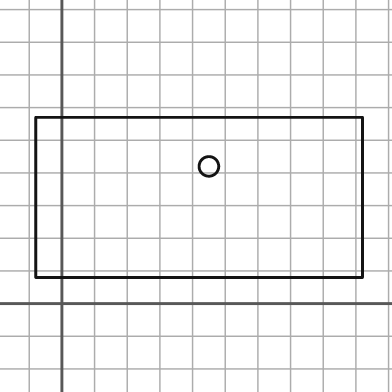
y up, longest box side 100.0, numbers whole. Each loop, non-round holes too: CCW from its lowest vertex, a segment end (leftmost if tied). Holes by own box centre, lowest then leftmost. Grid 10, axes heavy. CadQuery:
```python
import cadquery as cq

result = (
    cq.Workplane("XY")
    .moveTo(-8.0, 8.0)
    .lineTo(92.0, 8.0)
    .lineTo(92.0, 57.0)
    .lineTo(-8.0, 57.0)
    .close()
    .moveTo(45.0, 42.0)
    .circle(3.0)
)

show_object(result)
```